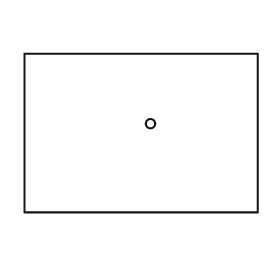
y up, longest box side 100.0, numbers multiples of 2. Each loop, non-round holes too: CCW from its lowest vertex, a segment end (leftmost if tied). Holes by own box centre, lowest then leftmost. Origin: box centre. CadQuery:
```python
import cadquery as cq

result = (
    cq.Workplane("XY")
    .moveTo(-50.0, -34.0)
    .lineTo(50.0, -34.0)
    .lineTo(50.0, 34.0)
    .lineTo(-50.0, 34.0)
    .close()
    .moveTo(4.0, 4.0)
    .circle(2.0)
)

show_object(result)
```